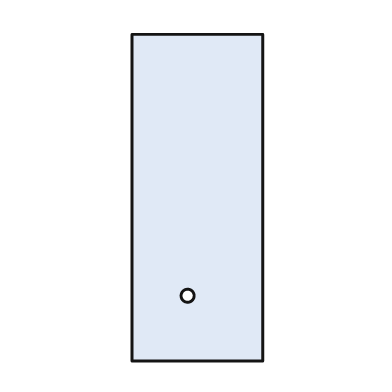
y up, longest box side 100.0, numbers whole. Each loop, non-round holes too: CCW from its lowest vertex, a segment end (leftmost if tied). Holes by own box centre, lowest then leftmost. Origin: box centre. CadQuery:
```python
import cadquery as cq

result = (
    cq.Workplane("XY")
    .moveTo(-20.0, -50.0)
    .lineTo(20.0, -50.0)
    .lineTo(20.0, 50.0)
    .lineTo(-20.0, 50.0)
    .close()
    .moveTo(-3.0, -30.0)
    .circle(2.0)
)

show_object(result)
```